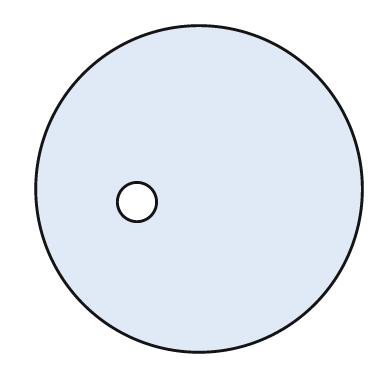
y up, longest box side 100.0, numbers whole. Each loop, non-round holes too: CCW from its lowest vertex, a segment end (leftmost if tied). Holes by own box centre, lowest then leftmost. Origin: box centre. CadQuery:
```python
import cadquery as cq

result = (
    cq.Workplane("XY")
    .moveTo(0.0, 0.0)
    .circle(50.0)
    .moveTo(-19.0, -4.0)
    .circle(6.0)
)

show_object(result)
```